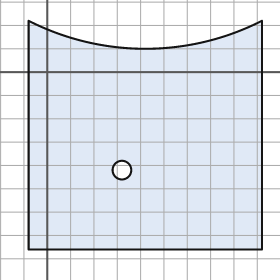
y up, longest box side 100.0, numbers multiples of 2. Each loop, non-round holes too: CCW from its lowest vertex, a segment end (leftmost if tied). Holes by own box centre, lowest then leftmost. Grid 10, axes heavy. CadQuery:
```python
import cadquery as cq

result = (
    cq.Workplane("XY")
    .moveTo(-8.0, -76.0)
    .lineTo(92.0, -76.0)
    .lineTo(92.0, 22.0)
    .threePointArc((42.0, 10.0), (-8.0, 22.0))
    .close()
    .moveTo(32.0, -42.0)
    .circle(4.0)
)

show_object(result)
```